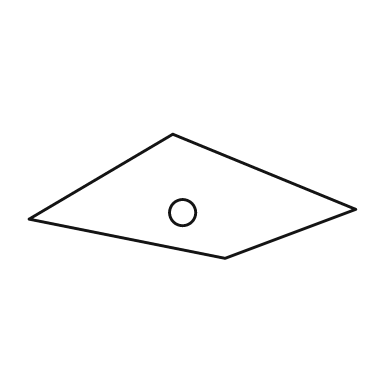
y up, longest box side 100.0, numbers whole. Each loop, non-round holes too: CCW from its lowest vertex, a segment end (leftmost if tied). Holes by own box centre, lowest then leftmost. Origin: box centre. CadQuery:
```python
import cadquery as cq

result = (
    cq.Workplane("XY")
    .moveTo(10.0, -19.0)
    .lineTo(50.0, -4.0)
    .lineTo(-6.0, 19.0)
    .lineTo(-50.0, -7.0)
    .close()
    .moveTo(-3.0, -5.0)
    .circle(4.0)
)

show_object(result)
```